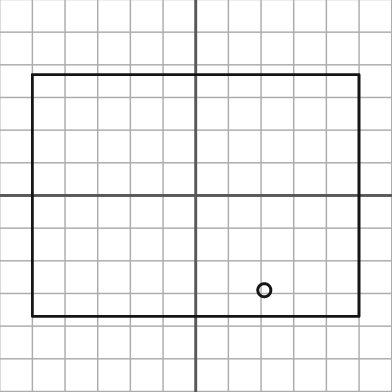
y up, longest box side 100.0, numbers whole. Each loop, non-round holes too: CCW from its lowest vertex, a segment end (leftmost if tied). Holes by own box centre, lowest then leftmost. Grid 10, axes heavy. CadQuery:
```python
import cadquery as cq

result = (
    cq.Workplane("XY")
    .moveTo(-50.0, -37.0)
    .lineTo(50.0, -37.0)
    .lineTo(50.0, 37.0)
    .lineTo(-50.0, 37.0)
    .close()
    .moveTo(21.0, -29.0)
    .circle(2.0)
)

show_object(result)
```